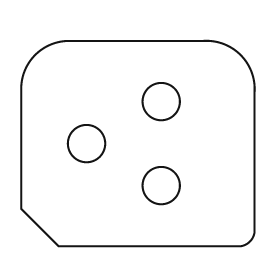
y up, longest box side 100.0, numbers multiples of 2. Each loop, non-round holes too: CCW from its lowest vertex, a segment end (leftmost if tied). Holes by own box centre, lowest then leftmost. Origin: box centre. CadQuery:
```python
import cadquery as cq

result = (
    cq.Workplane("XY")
    .moveTo(-34.0, -44.0)
    .lineTo(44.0, -44.0)
    .threePointArc((48.0, -42.0), (50.0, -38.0))
    .lineTo(50.0, 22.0)
    .threePointArc((44.0, 38.0), (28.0, 44.0))
    .lineTo(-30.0, 44.0)
    .threePointArc((-44.0, 38.0), (-50.0, 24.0))
    .lineTo(-50.0, -28.0)
    .close()
    .moveTo(10.0, -18.0)
    .circle(8.0)
    .moveTo(-22.0, 0.0)
    .circle(8.0)
    .moveTo(10.0, 18.0)
    .circle(8.0)
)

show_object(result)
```